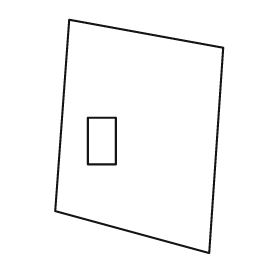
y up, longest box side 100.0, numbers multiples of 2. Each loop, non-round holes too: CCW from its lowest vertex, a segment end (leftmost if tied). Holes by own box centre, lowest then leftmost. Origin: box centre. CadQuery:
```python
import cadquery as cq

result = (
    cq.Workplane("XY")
    .moveTo(30.0, -50.0)
    .lineTo(36.0, 38.0)
    .lineTo(-30.0, 50.0)
    .lineTo(-36.0, -32.0)
    .close()
    .moveTo(-22.0, -12.0)
    .lineTo(-10.0, -12.0)
    .lineTo(-10.0, 8.0)
    .lineTo(-22.0, 8.0)
    .close()
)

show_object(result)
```